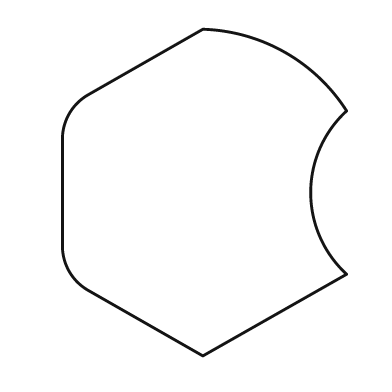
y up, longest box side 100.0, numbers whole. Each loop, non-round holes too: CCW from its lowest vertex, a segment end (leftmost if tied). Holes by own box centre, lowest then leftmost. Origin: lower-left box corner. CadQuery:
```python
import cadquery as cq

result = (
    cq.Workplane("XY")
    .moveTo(43.0, 0.0)
    .lineTo(87.0, 25.0)
    .threePointArc((76.0, 50.0), (87.0, 75.0))
    .threePointArc((68.0, 93.0), (43.0, 100.0))
    .lineTo(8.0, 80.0)
    .threePointArc((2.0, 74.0), (0.0, 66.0))
    .lineTo(0.0, 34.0)
    .threePointArc((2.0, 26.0), (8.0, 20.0))
    .close()
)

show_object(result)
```